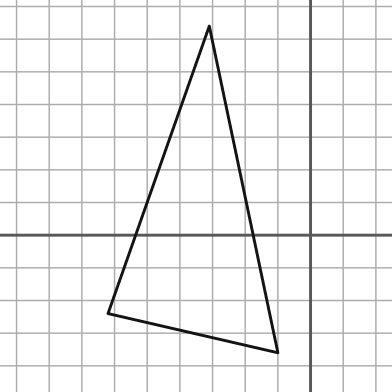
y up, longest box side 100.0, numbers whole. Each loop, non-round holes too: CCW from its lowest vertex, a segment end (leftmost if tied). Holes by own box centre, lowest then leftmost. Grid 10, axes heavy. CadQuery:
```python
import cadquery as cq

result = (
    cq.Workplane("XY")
    .moveTo(-10.0, -36.0)
    .lineTo(-31.0, 64.0)
    .lineTo(-62.0, -24.0)
    .close()
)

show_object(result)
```